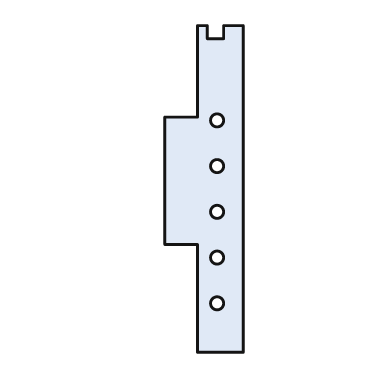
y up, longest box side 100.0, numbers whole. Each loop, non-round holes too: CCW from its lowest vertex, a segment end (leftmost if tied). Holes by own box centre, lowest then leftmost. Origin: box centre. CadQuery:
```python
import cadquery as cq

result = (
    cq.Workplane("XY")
    .moveTo(-2.0, -50.0)
    .lineTo(12.0, -50.0)
    .lineTo(12.0, 50.0)
    .lineTo(6.0, 50.0)
    .lineTo(6.0, 46.0)
    .lineTo(1.0, 46.0)
    .lineTo(1.0, 50.0)
    .lineTo(-2.0, 50.0)
    .lineTo(-2.0, 22.0)
    .lineTo(-12.0, 22.0)
    .lineTo(-12.0, -17.0)
    .lineTo(-2.0, -17.0)
    .close()
    .moveTo(4.0, -35.0)
    .circle(2.0)
    .moveTo(4.0, -21.0)
    .circle(2.0)
    .moveTo(4.0, -7.0)
    .circle(2.0)
    .moveTo(4.0, 7.0)
    .circle(2.0)
    .moveTo(4.0, 21.0)
    .circle(2.0)
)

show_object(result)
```